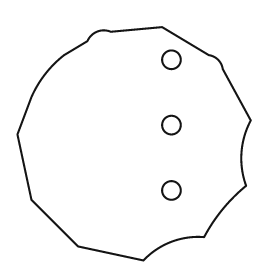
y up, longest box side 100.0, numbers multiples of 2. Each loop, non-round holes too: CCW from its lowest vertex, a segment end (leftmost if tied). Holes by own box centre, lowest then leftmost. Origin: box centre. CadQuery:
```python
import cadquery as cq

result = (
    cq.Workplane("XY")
    .moveTo(4.0, -50.0)
    .threePointArc((16.0, -42.0), (30.0, -40.0))
    .threePointArc((38.0, -28.0), (48.0, -18.0))
    .threePointArc((46.0, -4.0), (50.0, 10.0))
    .lineTo(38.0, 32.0)
    .threePointArc((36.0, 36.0), (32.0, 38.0))
    .lineTo(12.0, 50.0)
    .lineTo(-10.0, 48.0)
    .threePointArc((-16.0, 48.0), (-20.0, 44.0))
    .lineTo(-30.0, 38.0)
    .threePointArc((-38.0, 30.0), (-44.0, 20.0))
    .lineTo(-50.0, 4.0)
    .lineTo(-44.0, -24.0)
    .lineTo(-24.0, -44.0)
    .close()
    .moveTo(16.0, -20.0)
    .circle(4.0)
    .moveTo(16.0, 8.0)
    .circle(4.0)
    .moveTo(16.0, 36.0)
    .circle(4.0)
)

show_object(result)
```